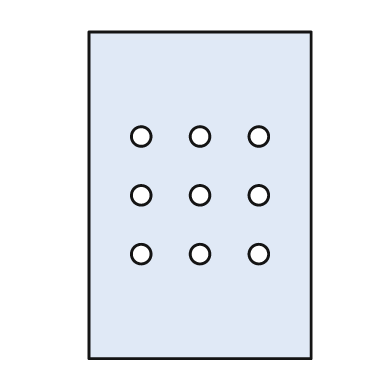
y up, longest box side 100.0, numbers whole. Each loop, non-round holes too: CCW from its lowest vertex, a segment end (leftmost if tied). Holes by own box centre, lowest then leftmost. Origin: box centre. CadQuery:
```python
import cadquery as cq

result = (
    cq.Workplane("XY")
    .moveTo(-34.0, -50.0)
    .lineTo(34.0, -50.0)
    .lineTo(34.0, 50.0)
    .lineTo(-34.0, 50.0)
    .close()
    .moveTo(-18.0, -18.0)
    .circle(3.0)
    .moveTo(0.0, -18.0)
    .circle(3.0)
    .moveTo(18.0, -18.0)
    .circle(3.0)
    .moveTo(-18.0, 0.0)
    .circle(3.0)
    .moveTo(0.0, 0.0)
    .circle(3.0)
    .moveTo(18.0, 0.0)
    .circle(3.0)
    .moveTo(-18.0, 18.0)
    .circle(3.0)
    .moveTo(0.0, 18.0)
    .circle(3.0)
    .moveTo(18.0, 18.0)
    .circle(3.0)
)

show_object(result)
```